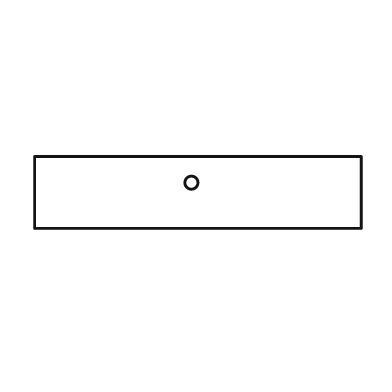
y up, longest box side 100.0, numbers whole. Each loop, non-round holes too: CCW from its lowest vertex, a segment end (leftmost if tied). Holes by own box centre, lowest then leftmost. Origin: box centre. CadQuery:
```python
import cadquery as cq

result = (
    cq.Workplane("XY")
    .moveTo(-50.0, -11.0)
    .lineTo(50.0, -11.0)
    .lineTo(50.0, 11.0)
    .lineTo(-50.0, 11.0)
    .close()
    .moveTo(-2.0, 3.0)
    .circle(2.0)
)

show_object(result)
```